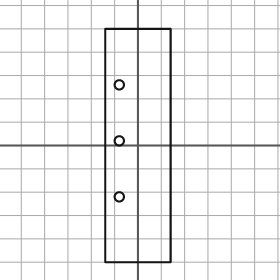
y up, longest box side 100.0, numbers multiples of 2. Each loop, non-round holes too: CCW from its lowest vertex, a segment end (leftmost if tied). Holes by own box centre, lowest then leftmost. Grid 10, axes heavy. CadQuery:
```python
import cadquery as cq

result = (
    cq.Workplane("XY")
    .moveTo(-14.0, -50.0)
    .lineTo(14.0, -50.0)
    .lineTo(14.0, 50.0)
    .lineTo(-14.0, 50.0)
    .close()
    .moveTo(-8.0, -22.0)
    .circle(2.0)
    .moveTo(-8.0, 2.0)
    .circle(2.0)
    .moveTo(-8.0, 26.0)
    .circle(2.0)
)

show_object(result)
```